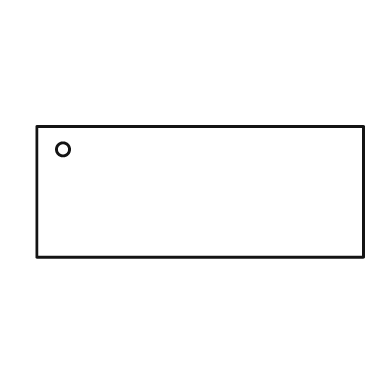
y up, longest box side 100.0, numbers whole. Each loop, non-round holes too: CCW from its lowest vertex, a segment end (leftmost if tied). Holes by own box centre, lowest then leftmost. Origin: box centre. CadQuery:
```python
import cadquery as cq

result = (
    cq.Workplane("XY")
    .moveTo(-50.0, -20.0)
    .lineTo(50.0, -20.0)
    .lineTo(50.0, 20.0)
    .lineTo(-50.0, 20.0)
    .close()
    .moveTo(-42.0, 13.0)
    .circle(2.0)
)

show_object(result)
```